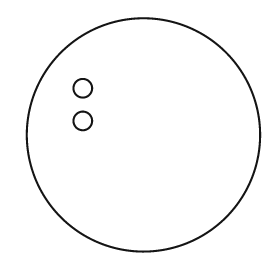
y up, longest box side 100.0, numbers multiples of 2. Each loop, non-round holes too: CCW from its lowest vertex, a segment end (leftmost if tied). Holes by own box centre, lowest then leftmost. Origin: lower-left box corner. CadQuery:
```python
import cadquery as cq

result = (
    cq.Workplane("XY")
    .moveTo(50.0, 50.0)
    .circle(50.0)
    .moveTo(24.0, 56.0)
    .circle(4.0)
    .moveTo(24.0, 70.0)
    .circle(4.0)
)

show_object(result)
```